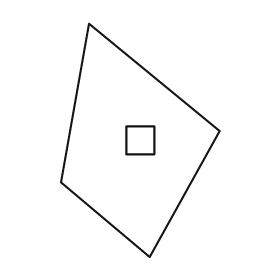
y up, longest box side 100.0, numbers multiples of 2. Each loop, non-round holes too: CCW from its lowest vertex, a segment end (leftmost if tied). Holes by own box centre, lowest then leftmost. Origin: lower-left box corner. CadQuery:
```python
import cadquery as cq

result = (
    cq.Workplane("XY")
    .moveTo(38.0, 0.0)
    .lineTo(68.0, 54.0)
    .lineTo(12.0, 100.0)
    .lineTo(0.0, 32.0)
    .close()
    .moveTo(28.0, 44.0)
    .lineTo(40.0, 44.0)
    .lineTo(40.0, 56.0)
    .lineTo(28.0, 56.0)
    .close()
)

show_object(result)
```